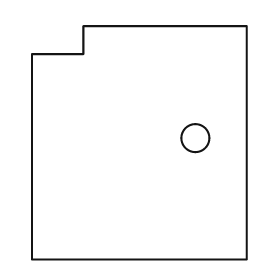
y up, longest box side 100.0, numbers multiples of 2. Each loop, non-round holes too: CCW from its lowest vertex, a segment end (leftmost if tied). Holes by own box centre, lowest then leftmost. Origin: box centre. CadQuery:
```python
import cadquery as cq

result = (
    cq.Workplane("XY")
    .moveTo(-46.0, -50.0)
    .lineTo(46.0, -50.0)
    .lineTo(46.0, 50.0)
    .lineTo(-24.0, 50.0)
    .lineTo(-24.0, 38.0)
    .lineTo(-46.0, 38.0)
    .close()
    .moveTo(24.0, 2.0)
    .circle(6.0)
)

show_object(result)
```